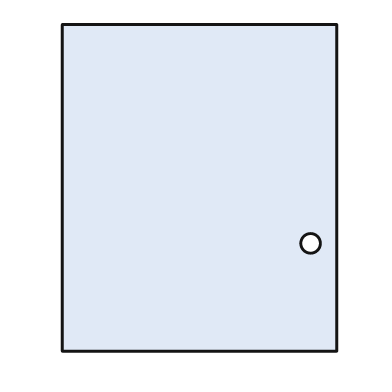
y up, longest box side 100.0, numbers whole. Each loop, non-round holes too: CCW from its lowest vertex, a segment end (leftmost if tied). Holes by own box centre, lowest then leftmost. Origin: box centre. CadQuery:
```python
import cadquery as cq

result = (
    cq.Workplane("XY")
    .moveTo(-42.0, -50.0)
    .lineTo(42.0, -50.0)
    .lineTo(42.0, 50.0)
    .lineTo(-42.0, 50.0)
    .close()
    .moveTo(34.0, -17.0)
    .circle(3.0)
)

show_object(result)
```